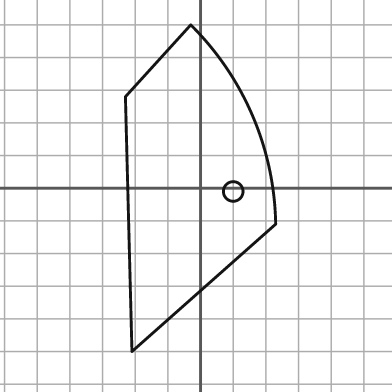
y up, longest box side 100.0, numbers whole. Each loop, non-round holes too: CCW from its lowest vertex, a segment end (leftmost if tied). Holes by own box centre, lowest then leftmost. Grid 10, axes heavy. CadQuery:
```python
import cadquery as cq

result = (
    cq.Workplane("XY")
    .moveTo(-21.0, -50.0)
    .lineTo(23.0, -11.0)
    .threePointArc((16.0, 22.0), (-3.0, 50.0))
    .lineTo(-23.0, 28.0)
    .close()
    .moveTo(10.0, -1.0)
    .circle(3.0)
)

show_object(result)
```